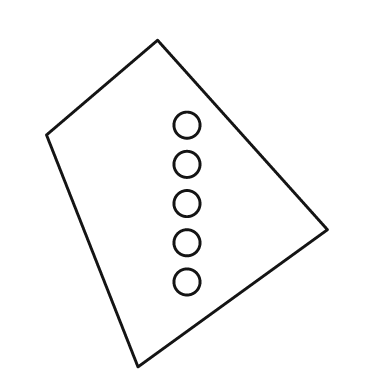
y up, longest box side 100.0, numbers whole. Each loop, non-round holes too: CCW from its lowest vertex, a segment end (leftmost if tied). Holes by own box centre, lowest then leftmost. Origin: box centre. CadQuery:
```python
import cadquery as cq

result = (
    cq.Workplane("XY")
    .moveTo(-15.0, -50.0)
    .lineTo(43.0, -8.0)
    .lineTo(-9.0, 50.0)
    .lineTo(-43.0, 21.0)
    .close()
    .moveTo(0.0, -24.0)
    .circle(4.0)
    .moveTo(0.0, -12.0)
    .circle(4.0)
    .moveTo(0.0, 0.0)
    .circle(4.0)
    .moveTo(0.0, 12.0)
    .circle(4.0)
    .moveTo(0.0, 24.0)
    .circle(4.0)
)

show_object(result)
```